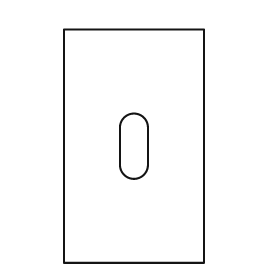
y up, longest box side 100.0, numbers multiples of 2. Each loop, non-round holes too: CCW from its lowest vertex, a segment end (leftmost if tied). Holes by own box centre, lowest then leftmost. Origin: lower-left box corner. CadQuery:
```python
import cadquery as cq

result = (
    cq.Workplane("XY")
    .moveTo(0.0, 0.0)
    .lineTo(60.0, 0.0)
    .lineTo(60.0, 100.0)
    .lineTo(0.0, 100.0)
    .close()
    .moveTo(24.0, 42.0)
    .threePointArc((30.0, 36.0), (36.0, 42.0))
    .lineTo(36.0, 58.0)
    .threePointArc((30.0, 64.0), (24.0, 58.0))
    .close()
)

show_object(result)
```